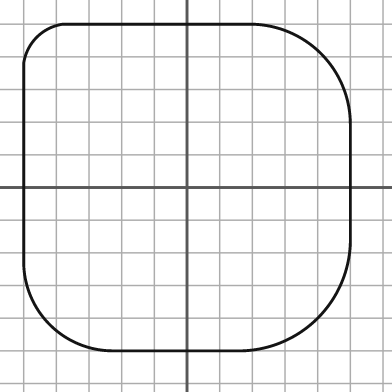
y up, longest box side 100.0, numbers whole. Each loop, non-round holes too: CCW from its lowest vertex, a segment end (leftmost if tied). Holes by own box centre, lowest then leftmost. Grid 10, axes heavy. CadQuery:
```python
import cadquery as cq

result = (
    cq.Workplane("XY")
    .moveTo(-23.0, -50.0)
    .lineTo(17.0, -50.0)
    .threePointArc((40.0, -40.0), (50.0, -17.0))
    .lineTo(50.0, 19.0)
    .threePointArc((41.0, 41.0), (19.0, 50.0))
    .lineTo(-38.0, 50.0)
    .threePointArc((-46.0, 46.0), (-50.0, 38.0))
    .lineTo(-50.0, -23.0)
    .threePointArc((-42.0, -42.0), (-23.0, -50.0))
    .close()
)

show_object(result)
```